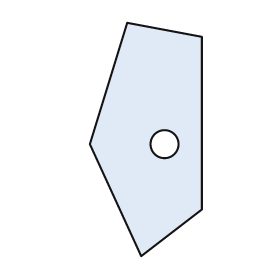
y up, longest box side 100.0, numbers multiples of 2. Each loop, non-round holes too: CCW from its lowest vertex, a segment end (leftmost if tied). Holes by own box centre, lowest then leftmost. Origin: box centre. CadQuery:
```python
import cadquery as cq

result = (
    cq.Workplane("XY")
    .moveTo(-2.0, -50.0)
    .lineTo(24.0, -30.0)
    .lineTo(24.0, 44.0)
    .lineTo(-8.0, 50.0)
    .lineTo(-24.0, -2.0)
    .close()
    .moveTo(8.0, -2.0)
    .circle(6.0)
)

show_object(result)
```